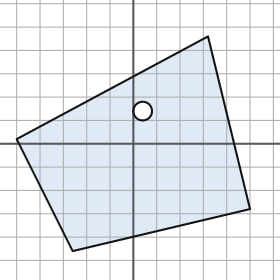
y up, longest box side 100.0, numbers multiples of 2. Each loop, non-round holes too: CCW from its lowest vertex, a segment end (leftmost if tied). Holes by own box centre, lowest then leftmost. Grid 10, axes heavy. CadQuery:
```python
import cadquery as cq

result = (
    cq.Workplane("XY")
    .moveTo(-26.0, -46.0)
    .lineTo(50.0, -28.0)
    .lineTo(32.0, 46.0)
    .lineTo(-50.0, 2.0)
    .close()
    .moveTo(4.0, 14.0)
    .circle(4.0)
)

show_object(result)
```